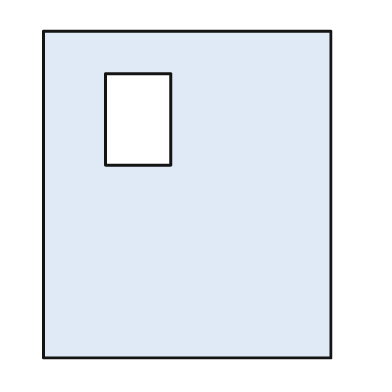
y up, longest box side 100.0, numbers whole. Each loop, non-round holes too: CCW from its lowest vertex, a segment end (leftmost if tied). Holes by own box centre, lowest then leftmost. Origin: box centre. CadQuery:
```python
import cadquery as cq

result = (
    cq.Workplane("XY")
    .moveTo(-44.0, -50.0)
    .lineTo(44.0, -50.0)
    .lineTo(44.0, 50.0)
    .lineTo(-44.0, 50.0)
    .close()
    .moveTo(-25.0, 9.0)
    .lineTo(-5.0, 9.0)
    .lineTo(-5.0, 37.0)
    .lineTo(-25.0, 37.0)
    .close()
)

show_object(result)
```